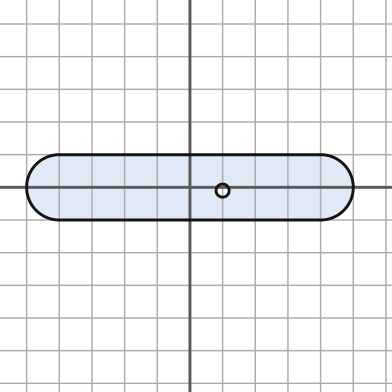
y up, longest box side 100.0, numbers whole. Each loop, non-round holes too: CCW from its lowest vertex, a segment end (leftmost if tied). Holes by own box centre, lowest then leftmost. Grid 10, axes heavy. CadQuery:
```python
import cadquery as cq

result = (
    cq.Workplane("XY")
    .moveTo(-40.0, -10.0)
    .lineTo(40.0, -10.0)
    .threePointArc((50.0, 0.0), (40.0, 10.0))
    .lineTo(-40.0, 10.0)
    .threePointArc((-50.0, 0.0), (-40.0, -10.0))
    .close()
    .moveTo(10.0, -1.0)
    .circle(2.0)
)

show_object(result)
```